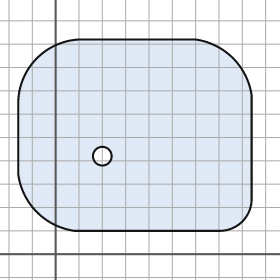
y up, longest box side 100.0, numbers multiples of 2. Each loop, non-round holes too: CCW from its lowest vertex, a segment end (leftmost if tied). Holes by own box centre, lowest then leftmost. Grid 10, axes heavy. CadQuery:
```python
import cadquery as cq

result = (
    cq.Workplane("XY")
    .moveTo(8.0, 10.0)
    .lineTo(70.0, 10.0)
    .threePointArc((80.0, 14.0), (84.0, 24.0))
    .lineTo(84.0, 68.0)
    .threePointArc((76.0, 84.0), (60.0, 92.0))
    .lineTo(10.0, 92.0)
    .threePointArc((-8.0, 84.0), (-16.0, 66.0))
    .lineTo(-16.0, 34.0)
    .threePointArc((-8.0, 18.0), (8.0, 10.0))
    .close()
    .moveTo(20.0, 42.0)
    .circle(4.0)
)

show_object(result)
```